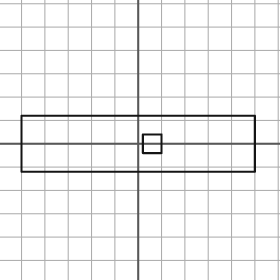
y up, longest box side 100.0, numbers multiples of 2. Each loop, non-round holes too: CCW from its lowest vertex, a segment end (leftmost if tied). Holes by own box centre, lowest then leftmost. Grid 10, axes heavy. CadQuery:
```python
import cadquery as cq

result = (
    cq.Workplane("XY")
    .moveTo(-50.0, -12.0)
    .lineTo(50.0, -12.0)
    .lineTo(50.0, 12.0)
    .lineTo(-50.0, 12.0)
    .close()
    .moveTo(2.0, -4.0)
    .lineTo(10.0, -4.0)
    .lineTo(10.0, 4.0)
    .lineTo(2.0, 4.0)
    .close()
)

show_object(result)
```